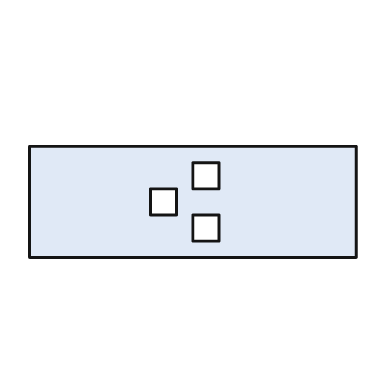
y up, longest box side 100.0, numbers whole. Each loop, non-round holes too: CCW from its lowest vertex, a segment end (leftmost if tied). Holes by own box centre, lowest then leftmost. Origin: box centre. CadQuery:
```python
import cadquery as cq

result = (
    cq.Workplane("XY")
    .moveTo(-50.0, -17.0)
    .lineTo(50.0, -17.0)
    .lineTo(50.0, 17.0)
    .lineTo(-50.0, 17.0)
    .close()
    .moveTo(0.0, -12.0)
    .lineTo(8.0, -12.0)
    .lineTo(8.0, -4.0)
    .lineTo(0.0, -4.0)
    .close()
    .moveTo(-13.0, -4.0)
    .lineTo(-5.0, -4.0)
    .lineTo(-5.0, 4.0)
    .lineTo(-13.0, 4.0)
    .close()
    .moveTo(0.0, 4.0)
    .lineTo(8.0, 4.0)
    .lineTo(8.0, 12.0)
    .lineTo(0.0, 12.0)
    .close()
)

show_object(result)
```